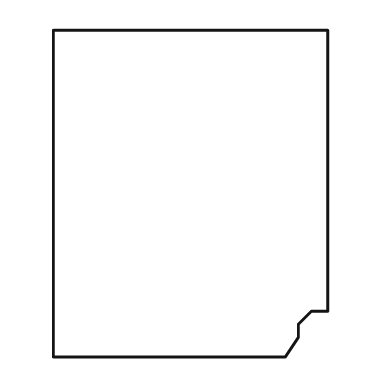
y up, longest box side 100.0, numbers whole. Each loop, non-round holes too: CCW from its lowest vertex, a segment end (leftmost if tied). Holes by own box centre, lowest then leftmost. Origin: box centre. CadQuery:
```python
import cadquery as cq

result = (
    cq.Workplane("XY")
    .moveTo(-42.0, -50.0)
    .lineTo(29.0, -50.0)
    .lineTo(33.0, -44.0)
    .lineTo(33.0, -40.0)
    .lineTo(37.0, -36.0)
    .lineTo(42.0, -36.0)
    .lineTo(42.0, 50.0)
    .lineTo(-42.0, 50.0)
    .close()
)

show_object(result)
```